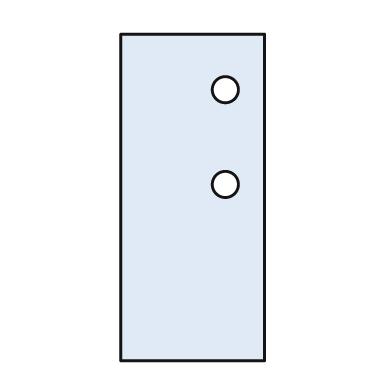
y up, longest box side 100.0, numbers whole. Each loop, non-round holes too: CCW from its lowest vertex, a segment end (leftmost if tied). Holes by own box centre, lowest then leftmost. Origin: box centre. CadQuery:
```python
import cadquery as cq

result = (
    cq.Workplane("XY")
    .moveTo(-22.0, -50.0)
    .lineTo(22.0, -50.0)
    .lineTo(22.0, 50.0)
    .lineTo(-22.0, 50.0)
    .close()
    .moveTo(10.0, 4.0)
    .circle(4.0)
    .moveTo(10.0, 33.0)
    .circle(4.0)
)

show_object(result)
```